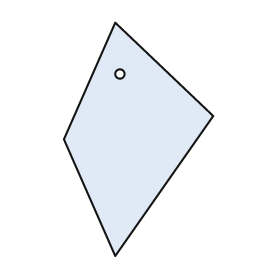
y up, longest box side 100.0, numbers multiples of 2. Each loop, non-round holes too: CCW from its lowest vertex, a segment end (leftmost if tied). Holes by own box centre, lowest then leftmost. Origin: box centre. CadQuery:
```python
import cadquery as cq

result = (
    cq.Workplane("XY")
    .moveTo(-10.0, -50.0)
    .lineTo(32.0, 10.0)
    .lineTo(-10.0, 50.0)
    .lineTo(-32.0, 0.0)
    .close()
    .moveTo(-8.0, 28.0)
    .circle(2.0)
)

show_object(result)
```